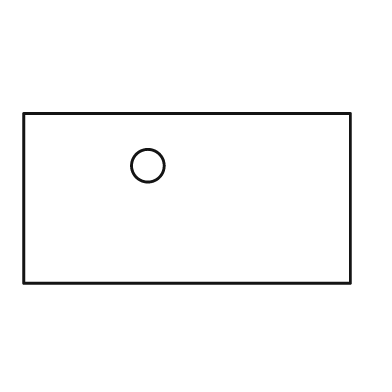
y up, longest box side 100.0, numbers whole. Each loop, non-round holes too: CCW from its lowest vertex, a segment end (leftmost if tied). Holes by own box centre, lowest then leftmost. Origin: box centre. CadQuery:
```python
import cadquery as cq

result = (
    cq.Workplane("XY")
    .moveTo(-50.0, -26.0)
    .lineTo(50.0, -26.0)
    .lineTo(50.0, 26.0)
    .lineTo(-50.0, 26.0)
    .close()
    .moveTo(-12.0, 10.0)
    .circle(5.0)
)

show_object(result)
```